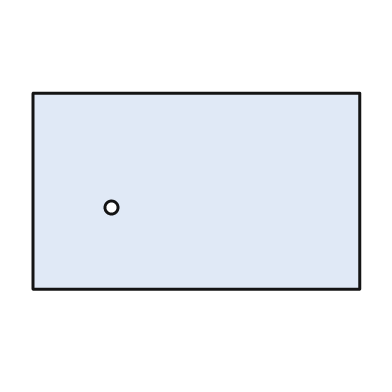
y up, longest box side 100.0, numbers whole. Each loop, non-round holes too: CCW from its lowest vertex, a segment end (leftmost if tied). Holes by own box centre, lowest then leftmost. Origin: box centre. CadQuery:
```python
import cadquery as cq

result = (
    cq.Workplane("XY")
    .moveTo(-50.0, -30.0)
    .lineTo(50.0, -30.0)
    .lineTo(50.0, 30.0)
    .lineTo(-50.0, 30.0)
    .close()
    .moveTo(-26.0, -5.0)
    .circle(2.0)
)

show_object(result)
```